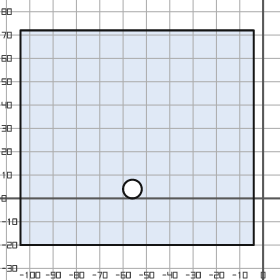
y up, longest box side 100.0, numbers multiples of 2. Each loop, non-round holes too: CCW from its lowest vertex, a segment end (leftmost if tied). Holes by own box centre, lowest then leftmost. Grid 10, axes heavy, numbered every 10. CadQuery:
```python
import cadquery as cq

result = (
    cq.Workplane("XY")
    .moveTo(-104.0, -20.0)
    .lineTo(-4.0, -20.0)
    .lineTo(-4.0, 72.0)
    .lineTo(-104.0, 72.0)
    .close()
    .moveTo(-56.0, 4.0)
    .circle(4.0)
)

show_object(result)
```